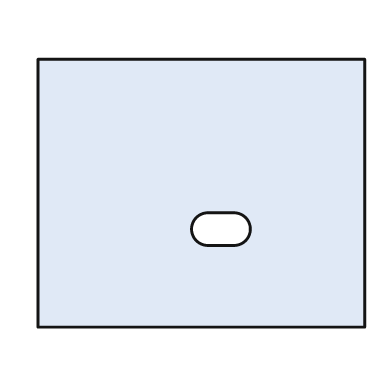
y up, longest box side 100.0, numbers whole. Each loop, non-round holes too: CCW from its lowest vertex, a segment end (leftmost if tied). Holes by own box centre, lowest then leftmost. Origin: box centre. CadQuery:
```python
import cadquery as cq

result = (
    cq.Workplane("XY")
    .moveTo(-50.0, -41.0)
    .lineTo(50.0, -41.0)
    .lineTo(50.0, 41.0)
    .lineTo(-50.0, 41.0)
    .close()
    .moveTo(2.0, -16.0)
    .lineTo(10.0, -16.0)
    .threePointArc((15.0, -11.0), (10.0, -6.0))
    .lineTo(2.0, -6.0)
    .threePointArc((-3.0, -11.0), (2.0, -16.0))
    .close()
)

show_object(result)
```